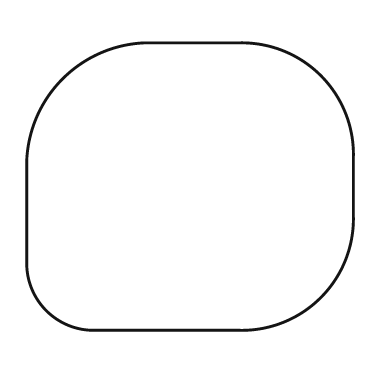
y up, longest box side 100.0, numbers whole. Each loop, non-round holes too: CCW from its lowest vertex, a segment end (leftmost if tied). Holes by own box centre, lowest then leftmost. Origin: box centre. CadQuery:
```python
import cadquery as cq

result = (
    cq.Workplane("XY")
    .moveTo(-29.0, -44.0)
    .lineTo(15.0, -44.0)
    .threePointArc((40.0, -34.0), (50.0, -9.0))
    .lineTo(50.0, 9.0)
    .threePointArc((40.0, 34.0), (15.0, 44.0))
    .lineTo(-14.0, 44.0)
    .threePointArc((-39.0, 33.0), (-50.0, 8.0))
    .lineTo(-50.0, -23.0)
    .threePointArc((-44.0, -38.0), (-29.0, -44.0))
    .close()
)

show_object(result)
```